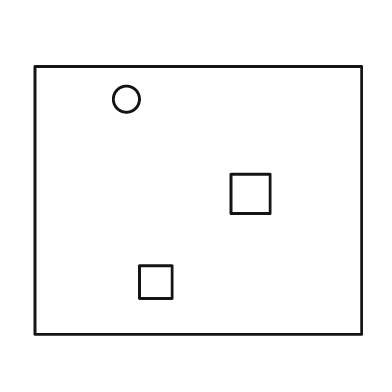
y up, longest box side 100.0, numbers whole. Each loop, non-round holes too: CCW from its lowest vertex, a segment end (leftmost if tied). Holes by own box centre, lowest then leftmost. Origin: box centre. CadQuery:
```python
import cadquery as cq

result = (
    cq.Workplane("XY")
    .moveTo(-50.0, -41.0)
    .lineTo(50.0, -41.0)
    .lineTo(50.0, 41.0)
    .lineTo(-50.0, 41.0)
    .close()
    .moveTo(-18.0, -30.0)
    .lineTo(-8.0, -30.0)
    .lineTo(-8.0, -20.0)
    .lineTo(-18.0, -20.0)
    .close()
    .moveTo(10.0, -4.0)
    .lineTo(22.0, -4.0)
    .lineTo(22.0, 8.0)
    .lineTo(10.0, 8.0)
    .close()
    .moveTo(-22.0, 31.0)
    .circle(4.0)
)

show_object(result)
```